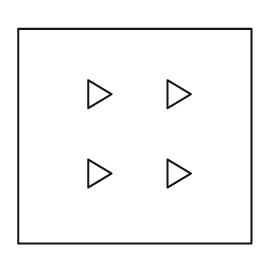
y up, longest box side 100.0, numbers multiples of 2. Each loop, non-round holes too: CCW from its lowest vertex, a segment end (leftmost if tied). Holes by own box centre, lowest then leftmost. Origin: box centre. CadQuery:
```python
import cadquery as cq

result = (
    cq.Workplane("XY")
    .moveTo(-50.0, -46.0)
    .lineTo(50.0, -46.0)
    .lineTo(50.0, 46.0)
    .lineTo(-50.0, 46.0)
    .close()
    .moveTo(-20.0, -22.0)
    .lineTo(-10.0, -16.0)
    .lineTo(-20.0, -10.0)
    .close()
    .moveTo(14.0, -22.0)
    .lineTo(24.0, -16.0)
    .lineTo(14.0, -10.0)
    .close()
    .moveTo(-20.0, 12.0)
    .lineTo(-10.0, 18.0)
    .lineTo(-20.0, 24.0)
    .close()
    .moveTo(14.0, 12.0)
    .lineTo(24.0, 18.0)
    .lineTo(14.0, 24.0)
    .close()
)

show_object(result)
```